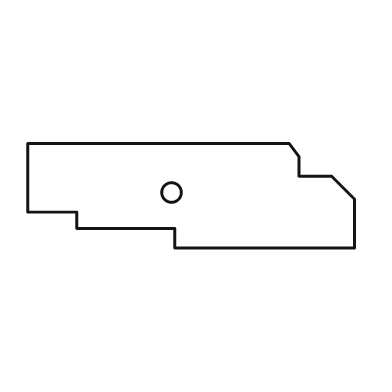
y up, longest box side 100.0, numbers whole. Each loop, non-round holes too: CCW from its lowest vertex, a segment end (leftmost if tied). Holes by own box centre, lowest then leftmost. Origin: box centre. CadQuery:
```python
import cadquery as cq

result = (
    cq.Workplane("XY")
    .moveTo(-5.0, -16.0)
    .lineTo(50.0, -16.0)
    .lineTo(50.0, -1.0)
    .lineTo(43.0, 6.0)
    .lineTo(33.0, 6.0)
    .lineTo(33.0, 12.0)
    .lineTo(30.0, 16.0)
    .lineTo(-50.0, 16.0)
    .lineTo(-50.0, -5.0)
    .lineTo(-35.0, -5.0)
    .lineTo(-35.0, -10.0)
    .lineTo(-5.0, -10.0)
    .close()
    .moveTo(-6.0, 1.0)
    .circle(3.0)
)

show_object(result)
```